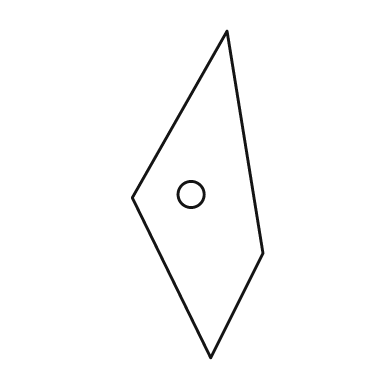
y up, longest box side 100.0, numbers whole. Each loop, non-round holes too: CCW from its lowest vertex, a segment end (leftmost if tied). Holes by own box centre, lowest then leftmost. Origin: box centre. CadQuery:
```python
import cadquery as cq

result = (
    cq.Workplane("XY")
    .moveTo(4.0, -50.0)
    .lineTo(20.0, -18.0)
    .lineTo(9.0, 50.0)
    .lineTo(-20.0, -1.0)
    .close()
    .moveTo(-2.0, 0.0)
    .circle(4.0)
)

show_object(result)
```